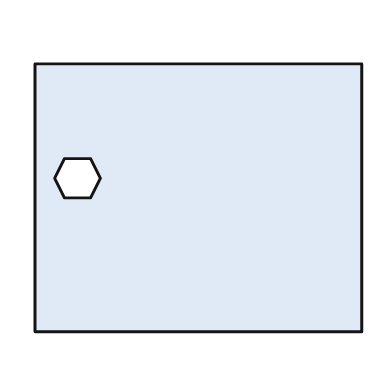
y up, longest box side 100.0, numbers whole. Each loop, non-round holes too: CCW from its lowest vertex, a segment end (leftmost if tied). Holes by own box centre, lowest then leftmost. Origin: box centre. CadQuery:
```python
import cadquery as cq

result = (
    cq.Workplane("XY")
    .moveTo(-50.0, -41.0)
    .lineTo(50.0, -41.0)
    .lineTo(50.0, 41.0)
    .lineTo(-50.0, 41.0)
    .close()
    .moveTo(-41.0, 0.0)
    .lineTo(-33.0, 0.0)
    .lineTo(-30.0, 6.0)
    .lineTo(-33.0, 12.0)
    .lineTo(-41.0, 12.0)
    .lineTo(-44.0, 6.0)
    .close()
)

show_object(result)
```